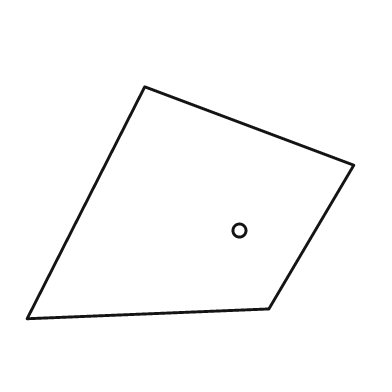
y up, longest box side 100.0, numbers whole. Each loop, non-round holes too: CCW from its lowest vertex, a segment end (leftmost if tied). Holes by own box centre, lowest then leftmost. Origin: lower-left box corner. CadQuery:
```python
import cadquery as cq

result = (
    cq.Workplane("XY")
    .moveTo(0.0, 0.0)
    .lineTo(74.0, 3.0)
    .lineTo(100.0, 47.0)
    .lineTo(36.0, 71.0)
    .close()
    .moveTo(65.0, 27.0)
    .circle(2.0)
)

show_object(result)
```